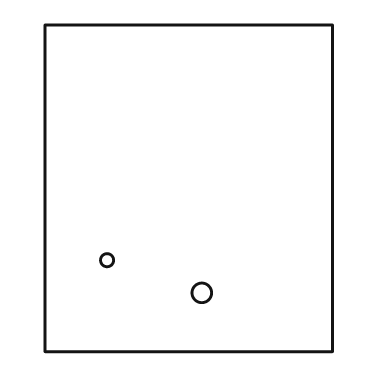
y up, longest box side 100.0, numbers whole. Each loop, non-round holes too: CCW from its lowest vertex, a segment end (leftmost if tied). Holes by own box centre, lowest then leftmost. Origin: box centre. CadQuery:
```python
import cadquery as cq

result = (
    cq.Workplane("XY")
    .moveTo(-44.0, -50.0)
    .lineTo(44.0, -50.0)
    .lineTo(44.0, 50.0)
    .lineTo(-44.0, 50.0)
    .close()
    .moveTo(4.0, -32.0)
    .circle(3.0)
    .moveTo(-25.0, -22.0)
    .circle(2.0)
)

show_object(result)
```